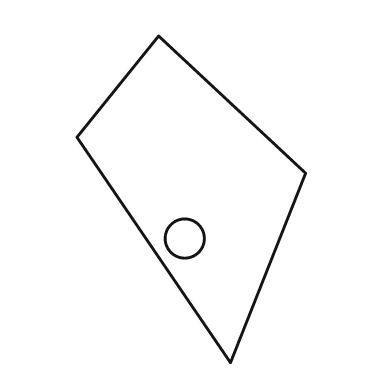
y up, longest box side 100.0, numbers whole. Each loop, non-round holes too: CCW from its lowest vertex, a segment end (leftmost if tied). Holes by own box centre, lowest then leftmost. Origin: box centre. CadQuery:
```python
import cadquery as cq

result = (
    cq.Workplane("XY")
    .moveTo(12.0, -50.0)
    .lineTo(35.0, 8.0)
    .lineTo(-10.0, 50.0)
    .lineTo(-35.0, 19.0)
    .close()
    .moveTo(-2.0, -12.0)
    .circle(6.0)
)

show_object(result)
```